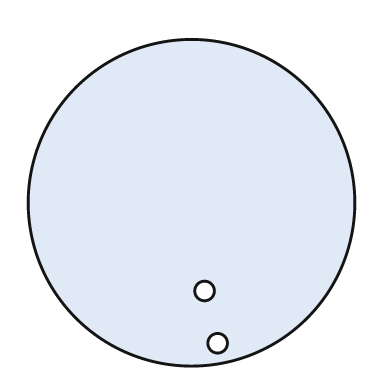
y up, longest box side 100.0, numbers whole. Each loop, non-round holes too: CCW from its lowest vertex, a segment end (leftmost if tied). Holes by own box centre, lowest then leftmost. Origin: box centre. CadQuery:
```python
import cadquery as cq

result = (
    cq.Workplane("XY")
    .moveTo(0.0, 0.0)
    .circle(50.0)
    .moveTo(8.0, -43.0)
    .circle(3.0)
    .moveTo(4.0, -27.0)
    .circle(3.0)
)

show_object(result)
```